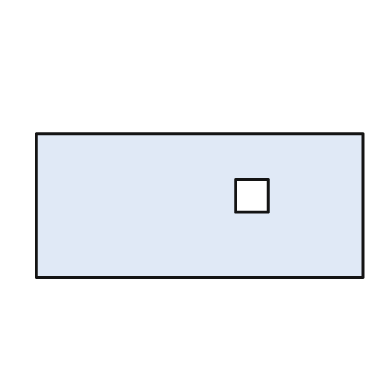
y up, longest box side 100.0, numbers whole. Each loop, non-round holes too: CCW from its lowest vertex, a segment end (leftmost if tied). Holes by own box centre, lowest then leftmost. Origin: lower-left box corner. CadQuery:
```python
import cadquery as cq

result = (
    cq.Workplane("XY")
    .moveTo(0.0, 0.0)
    .lineTo(100.0, 0.0)
    .lineTo(100.0, 44.0)
    .lineTo(0.0, 44.0)
    .close()
    .moveTo(61.0, 20.0)
    .lineTo(71.0, 20.0)
    .lineTo(71.0, 30.0)
    .lineTo(61.0, 30.0)
    .close()
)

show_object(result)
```